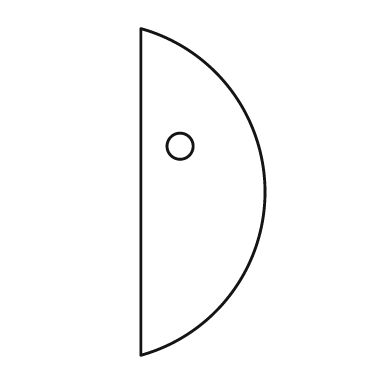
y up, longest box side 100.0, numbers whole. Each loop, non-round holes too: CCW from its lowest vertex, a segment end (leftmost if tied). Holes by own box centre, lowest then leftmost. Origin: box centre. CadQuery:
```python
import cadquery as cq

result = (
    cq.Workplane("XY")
    .moveTo(-19.0, -50.0)
    .threePointArc((19.0, 0.0), (-19.0, 50.0))
    .close()
    .moveTo(-7.0, 14.0)
    .circle(4.0)
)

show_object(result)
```